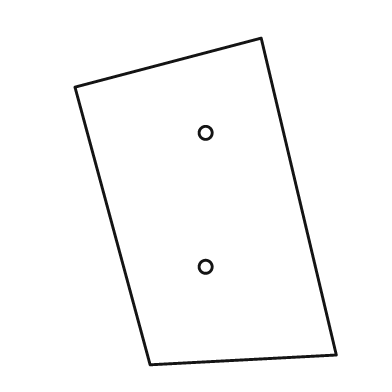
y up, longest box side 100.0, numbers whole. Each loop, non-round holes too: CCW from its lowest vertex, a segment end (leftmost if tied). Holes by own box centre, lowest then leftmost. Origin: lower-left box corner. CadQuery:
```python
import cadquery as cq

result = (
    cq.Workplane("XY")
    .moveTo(23.0, 0.0)
    .lineTo(80.0, 3.0)
    .lineTo(57.0, 100.0)
    .lineTo(0.0, 85.0)
    .close()
    .moveTo(40.0, 30.0)
    .circle(2.0)
    .moveTo(40.0, 71.0)
    .circle(2.0)
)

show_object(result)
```